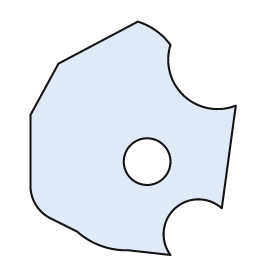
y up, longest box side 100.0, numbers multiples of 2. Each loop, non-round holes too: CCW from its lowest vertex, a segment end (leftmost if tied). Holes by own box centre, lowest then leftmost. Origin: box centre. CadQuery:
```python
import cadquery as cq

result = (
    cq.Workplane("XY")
    .moveTo(16.0, -50.0)
    .threePointArc((18.0, -30.0), (38.0, -30.0))
    .lineTo(44.0, 14.0)
    .threePointArc((22.0, 18.0), (16.0, 40.0))
    .threePointArc((10.0, 46.0), (2.0, 50.0))
    .lineTo(-32.0, 32.0)
    .lineTo(-44.0, 10.0)
    .lineTo(-44.0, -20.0)
    .threePointArc((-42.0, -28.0), (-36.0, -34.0))
    .lineTo(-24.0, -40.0)
    .threePointArc((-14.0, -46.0), (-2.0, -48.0))
    .close()
    .moveTo(6.0, -10.0)
    .circle(10.0)
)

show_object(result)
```